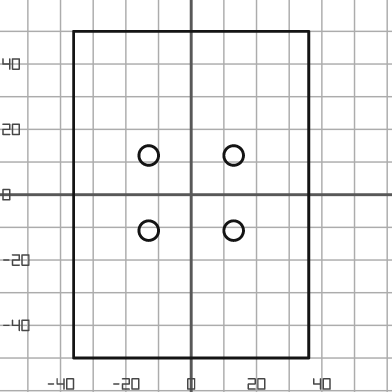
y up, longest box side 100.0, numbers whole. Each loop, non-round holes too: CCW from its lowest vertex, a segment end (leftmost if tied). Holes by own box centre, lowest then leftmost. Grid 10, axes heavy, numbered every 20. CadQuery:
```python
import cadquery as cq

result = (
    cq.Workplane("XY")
    .moveTo(-36.0, -50.0)
    .lineTo(36.0, -50.0)
    .lineTo(36.0, 50.0)
    .lineTo(-36.0, 50.0)
    .close()
    .moveTo(-13.0, -11.0)
    .circle(3.0)
    .moveTo(13.0, -11.0)
    .circle(3.0)
    .moveTo(-13.0, 12.0)
    .circle(3.0)
    .moveTo(13.0, 12.0)
    .circle(3.0)
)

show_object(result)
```